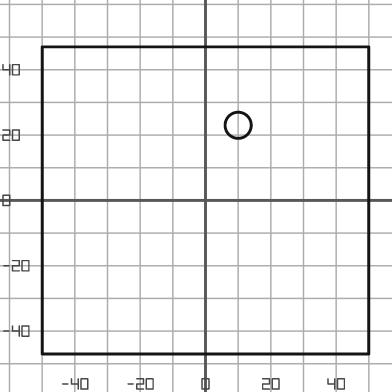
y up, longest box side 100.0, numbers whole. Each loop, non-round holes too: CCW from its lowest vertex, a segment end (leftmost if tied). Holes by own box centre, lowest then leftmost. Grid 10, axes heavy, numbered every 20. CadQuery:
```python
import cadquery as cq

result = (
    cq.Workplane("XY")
    .moveTo(-50.0, -47.0)
    .lineTo(50.0, -47.0)
    .lineTo(50.0, 47.0)
    .lineTo(-50.0, 47.0)
    .close()
    .moveTo(10.0, 23.0)
    .circle(4.0)
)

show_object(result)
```